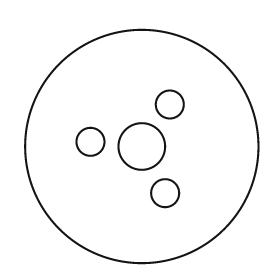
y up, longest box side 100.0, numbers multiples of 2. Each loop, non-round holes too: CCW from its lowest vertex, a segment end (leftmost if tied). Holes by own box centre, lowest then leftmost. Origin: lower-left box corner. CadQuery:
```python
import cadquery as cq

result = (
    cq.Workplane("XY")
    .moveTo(50.0, 50.0)
    .circle(50.0)
    .moveTo(60.0, 30.0)
    .circle(6.0)
    .moveTo(50.0, 50.0)
    .circle(10.0)
    .moveTo(28.0, 52.0)
    .circle(6.0)
    .moveTo(62.0, 68.0)
    .circle(6.0)
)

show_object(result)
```